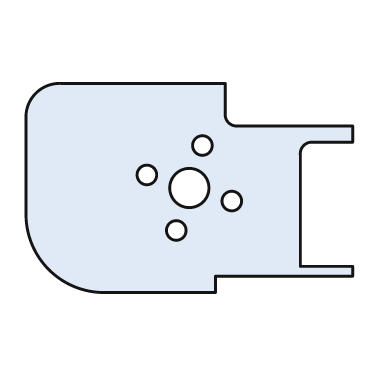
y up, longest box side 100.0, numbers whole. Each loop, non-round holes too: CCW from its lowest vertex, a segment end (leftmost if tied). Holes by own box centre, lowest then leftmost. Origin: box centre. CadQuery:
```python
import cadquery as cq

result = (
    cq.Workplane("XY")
    .moveTo(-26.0, -32.0)
    .lineTo(8.0, -32.0)
    .lineTo(8.0, -27.0)
    .lineTo(50.0, -27.0)
    .lineTo(50.0, -24.0)
    .lineTo(34.0, -24.0)
    .lineTo(34.0, 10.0)
    .threePointArc((35.0, 13.0), (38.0, 14.0))
    .lineTo(50.0, 14.0)
    .lineTo(50.0, 19.0)
    .lineTo(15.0, 19.0)
    .threePointArc((12.0, 20.0), (11.0, 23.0))
    .lineTo(11.0, 32.0)
    .lineTo(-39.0, 32.0)
    .threePointArc((-47.0, 29.0), (-50.0, 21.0))
    .lineTo(-50.0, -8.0)
    .threePointArc((-43.0, -25.0), (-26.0, -32.0))
    .close()
    .moveTo(-4.0, -13.0)
    .circle(3.0)
    .moveTo(13.0, -4.0)
    .circle(3.0)
    .moveTo(0.0, 0.0)
    .circle(6.0)
    .moveTo(-13.0, 4.0)
    .circle(3.0)
    .moveTo(4.0, 13.0)
    .circle(3.0)
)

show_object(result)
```